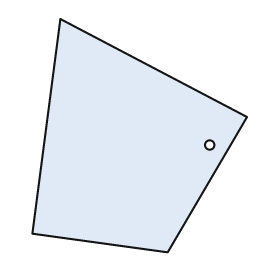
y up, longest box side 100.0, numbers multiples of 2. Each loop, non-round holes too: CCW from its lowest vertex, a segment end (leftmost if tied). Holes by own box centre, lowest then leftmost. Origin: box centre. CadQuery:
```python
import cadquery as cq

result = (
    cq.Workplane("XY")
    .moveTo(12.0, -50.0)
    .lineTo(46.0, 8.0)
    .lineTo(-34.0, 50.0)
    .lineTo(-46.0, -42.0)
    .close()
    .moveTo(30.0, -4.0)
    .circle(2.0)
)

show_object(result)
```